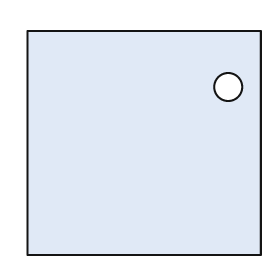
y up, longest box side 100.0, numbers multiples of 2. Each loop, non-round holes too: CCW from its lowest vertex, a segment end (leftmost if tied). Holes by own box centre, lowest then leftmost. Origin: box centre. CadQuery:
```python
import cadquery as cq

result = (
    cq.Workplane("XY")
    .moveTo(-50.0, -48.0)
    .lineTo(50.0, -48.0)
    .lineTo(50.0, 48.0)
    .lineTo(-50.0, 48.0)
    .close()
    .moveTo(36.0, 24.0)
    .circle(6.0)
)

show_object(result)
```